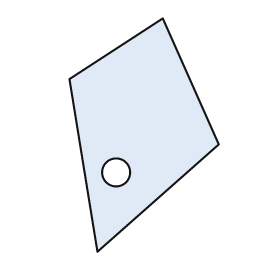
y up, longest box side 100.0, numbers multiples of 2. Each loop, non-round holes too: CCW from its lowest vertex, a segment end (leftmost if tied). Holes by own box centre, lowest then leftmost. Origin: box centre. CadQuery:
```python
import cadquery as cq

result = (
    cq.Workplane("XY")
    .moveTo(-20.0, -50.0)
    .lineTo(32.0, -4.0)
    .lineTo(8.0, 50.0)
    .lineTo(-32.0, 24.0)
    .close()
    .moveTo(-12.0, -16.0)
    .circle(6.0)
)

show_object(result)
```